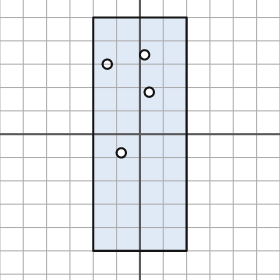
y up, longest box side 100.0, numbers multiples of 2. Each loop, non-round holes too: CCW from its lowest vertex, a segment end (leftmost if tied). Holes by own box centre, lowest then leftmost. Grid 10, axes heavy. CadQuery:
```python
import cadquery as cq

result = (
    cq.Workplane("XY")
    .moveTo(-20.0, -50.0)
    .lineTo(20.0, -50.0)
    .lineTo(20.0, 50.0)
    .lineTo(-20.0, 50.0)
    .close()
    .moveTo(-8.0, -8.0)
    .circle(2.0)
    .moveTo(4.0, 18.0)
    .circle(2.0)
    .moveTo(-14.0, 30.0)
    .circle(2.0)
    .moveTo(2.0, 34.0)
    .circle(2.0)
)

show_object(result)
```